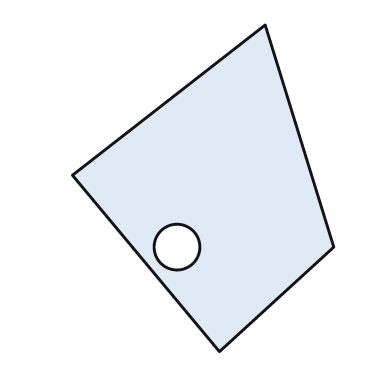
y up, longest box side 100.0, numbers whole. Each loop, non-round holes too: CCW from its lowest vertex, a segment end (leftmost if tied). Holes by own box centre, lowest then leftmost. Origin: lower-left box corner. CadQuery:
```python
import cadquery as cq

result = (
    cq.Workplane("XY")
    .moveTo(45.0, 0.0)
    .lineTo(80.0, 32.0)
    .lineTo(59.0, 100.0)
    .lineTo(0.0, 54.0)
    .close()
    .moveTo(32.0, 32.0)
    .circle(7.0)
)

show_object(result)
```